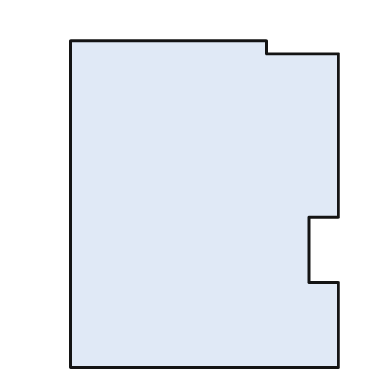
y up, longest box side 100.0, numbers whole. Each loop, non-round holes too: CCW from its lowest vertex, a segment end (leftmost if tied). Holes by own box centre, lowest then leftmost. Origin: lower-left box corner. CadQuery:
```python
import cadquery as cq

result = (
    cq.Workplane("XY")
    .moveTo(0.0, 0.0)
    .lineTo(82.0, 0.0)
    .lineTo(82.0, 26.0)
    .lineTo(73.0, 26.0)
    .lineTo(73.0, 46.0)
    .lineTo(82.0, 46.0)
    .lineTo(82.0, 96.0)
    .lineTo(60.0, 96.0)
    .lineTo(60.0, 100.0)
    .lineTo(0.0, 100.0)
    .close()
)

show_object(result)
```